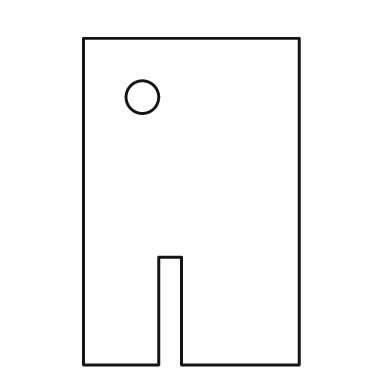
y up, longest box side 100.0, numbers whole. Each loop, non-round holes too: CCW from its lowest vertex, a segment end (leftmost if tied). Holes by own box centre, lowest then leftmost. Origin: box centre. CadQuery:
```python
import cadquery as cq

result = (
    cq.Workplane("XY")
    .moveTo(-33.0, -50.0)
    .lineTo(-10.0, -50.0)
    .lineTo(-10.0, -17.0)
    .lineTo(-3.0, -17.0)
    .lineTo(-3.0, -50.0)
    .lineTo(33.0, -50.0)
    .lineTo(33.0, 50.0)
    .lineTo(-33.0, 50.0)
    .close()
    .moveTo(-15.0, 32.0)
    .circle(5.0)
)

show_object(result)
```